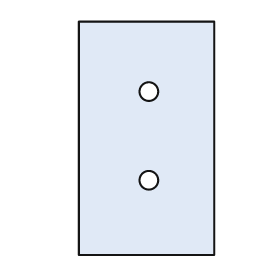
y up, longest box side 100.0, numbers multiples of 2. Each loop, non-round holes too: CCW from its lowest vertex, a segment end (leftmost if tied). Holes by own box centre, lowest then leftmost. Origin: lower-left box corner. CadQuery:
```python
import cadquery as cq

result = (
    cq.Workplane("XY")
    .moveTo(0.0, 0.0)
    .lineTo(58.0, 0.0)
    .lineTo(58.0, 100.0)
    .lineTo(0.0, 100.0)
    .close()
    .moveTo(30.0, 32.0)
    .circle(4.0)
    .moveTo(30.0, 70.0)
    .circle(4.0)
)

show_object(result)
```